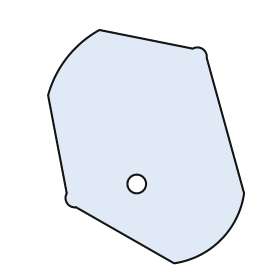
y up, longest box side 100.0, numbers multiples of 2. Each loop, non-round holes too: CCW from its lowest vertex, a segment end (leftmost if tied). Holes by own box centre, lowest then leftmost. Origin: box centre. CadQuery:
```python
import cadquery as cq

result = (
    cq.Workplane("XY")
    .moveTo(12.0, -50.0)
    .threePointArc((32.0, -40.0), (42.0, -20.0))
    .lineTo(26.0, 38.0)
    .threePointArc((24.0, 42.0), (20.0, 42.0))
    .lineTo(-20.0, 50.0)
    .threePointArc((-34.0, 38.0), (-42.0, 22.0))
    .lineTo(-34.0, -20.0)
    .threePointArc((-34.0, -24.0), (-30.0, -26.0))
    .close()
    .moveTo(-4.0, -16.0)
    .circle(4.0)
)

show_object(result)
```